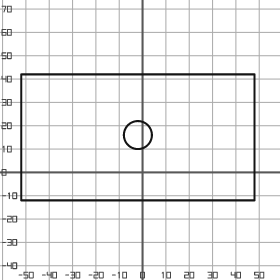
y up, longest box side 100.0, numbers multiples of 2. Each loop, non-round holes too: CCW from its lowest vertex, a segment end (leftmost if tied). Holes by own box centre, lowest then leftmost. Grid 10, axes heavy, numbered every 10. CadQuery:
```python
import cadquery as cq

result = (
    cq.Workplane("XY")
    .moveTo(-52.0, -12.0)
    .lineTo(48.0, -12.0)
    .lineTo(48.0, 42.0)
    .lineTo(-52.0, 42.0)
    .close()
    .moveTo(-2.0, 16.0)
    .circle(6.0)
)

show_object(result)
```